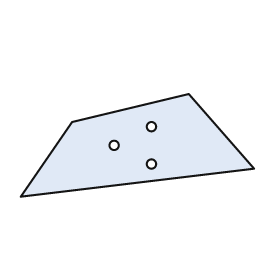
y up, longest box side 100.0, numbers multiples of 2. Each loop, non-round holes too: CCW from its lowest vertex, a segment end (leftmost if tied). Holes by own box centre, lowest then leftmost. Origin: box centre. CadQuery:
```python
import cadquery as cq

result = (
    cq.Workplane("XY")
    .moveTo(-50.0, -22.0)
    .lineTo(50.0, -10.0)
    .lineTo(22.0, 22.0)
    .lineTo(-28.0, 10.0)
    .close()
    .moveTo(6.0, -8.0)
    .circle(2.0)
    .moveTo(-10.0, 0.0)
    .circle(2.0)
    .moveTo(6.0, 8.0)
    .circle(2.0)
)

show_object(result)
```